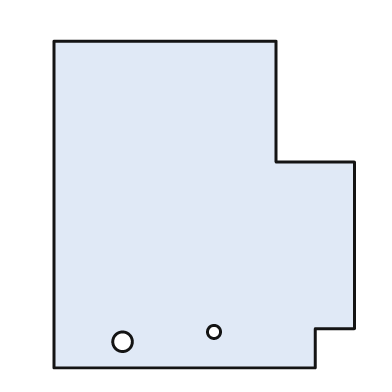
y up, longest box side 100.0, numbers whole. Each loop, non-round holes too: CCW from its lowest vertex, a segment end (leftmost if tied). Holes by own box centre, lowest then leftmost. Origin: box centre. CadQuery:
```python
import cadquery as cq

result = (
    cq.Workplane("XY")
    .moveTo(-46.0, -50.0)
    .lineTo(34.0, -50.0)
    .lineTo(34.0, -38.0)
    .lineTo(46.0, -38.0)
    .lineTo(46.0, 13.0)
    .lineTo(22.0, 13.0)
    .lineTo(22.0, 50.0)
    .lineTo(-46.0, 50.0)
    .close()
    .moveTo(-25.0, -42.0)
    .circle(3.0)
    .moveTo(3.0, -39.0)
    .circle(2.0)
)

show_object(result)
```